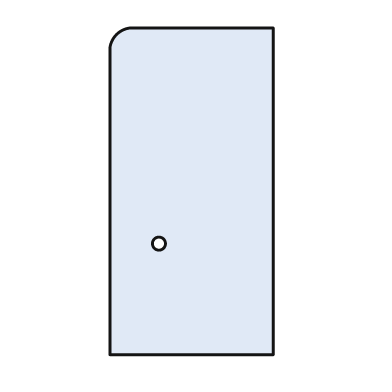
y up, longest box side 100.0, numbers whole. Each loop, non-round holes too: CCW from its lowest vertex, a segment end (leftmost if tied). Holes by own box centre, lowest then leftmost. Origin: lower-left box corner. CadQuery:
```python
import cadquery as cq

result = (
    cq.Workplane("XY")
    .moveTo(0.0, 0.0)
    .lineTo(50.0, 0.0)
    .lineTo(50.0, 100.0)
    .lineTo(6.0, 100.0)
    .threePointArc((2.0, 98.0), (0.0, 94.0))
    .close()
    .moveTo(15.0, 34.0)
    .circle(2.0)
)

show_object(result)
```